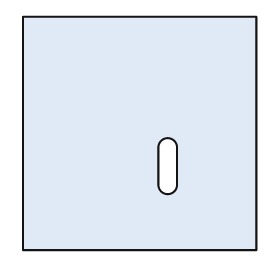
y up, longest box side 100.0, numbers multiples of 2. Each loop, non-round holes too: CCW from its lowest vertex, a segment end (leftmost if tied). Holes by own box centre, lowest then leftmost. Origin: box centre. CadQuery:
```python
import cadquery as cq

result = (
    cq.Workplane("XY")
    .moveTo(-50.0, -50.0)
    .lineTo(50.0, -50.0)
    .lineTo(50.0, 50.0)
    .lineTo(-50.0, 50.0)
    .close()
    .moveTo(8.0, -22.0)
    .threePointArc((12.0, -26.0), (16.0, -22.0))
    .lineTo(16.0, -6.0)
    .threePointArc((12.0, -2.0), (8.0, -6.0))
    .close()
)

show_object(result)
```